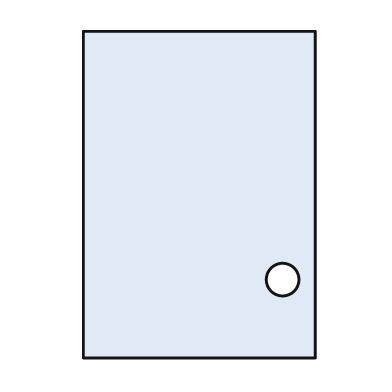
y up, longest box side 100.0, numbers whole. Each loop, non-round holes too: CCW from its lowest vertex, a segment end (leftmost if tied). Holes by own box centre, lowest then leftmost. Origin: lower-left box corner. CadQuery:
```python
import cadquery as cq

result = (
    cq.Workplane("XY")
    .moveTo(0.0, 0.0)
    .lineTo(71.0, 0.0)
    .lineTo(71.0, 100.0)
    .lineTo(0.0, 100.0)
    .close()
    .moveTo(61.0, 24.0)
    .circle(5.0)
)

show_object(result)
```